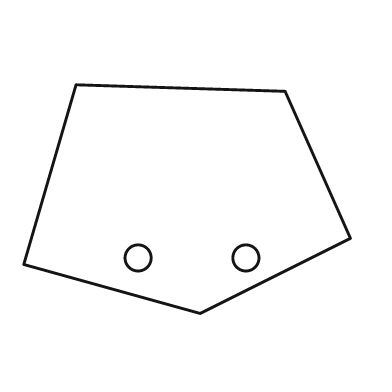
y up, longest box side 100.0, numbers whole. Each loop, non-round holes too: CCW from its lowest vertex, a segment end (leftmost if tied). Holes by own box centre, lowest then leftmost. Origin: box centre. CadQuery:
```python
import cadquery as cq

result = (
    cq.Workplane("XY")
    .moveTo(4.0, -35.0)
    .lineTo(50.0, -12.0)
    .lineTo(30.0, 33.0)
    .lineTo(-34.0, 35.0)
    .lineTo(-50.0, -20.0)
    .close()
    .moveTo(-15.0, -18.0)
    .circle(4.0)
    .moveTo(18.0, -18.0)
    .circle(4.0)
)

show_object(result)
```